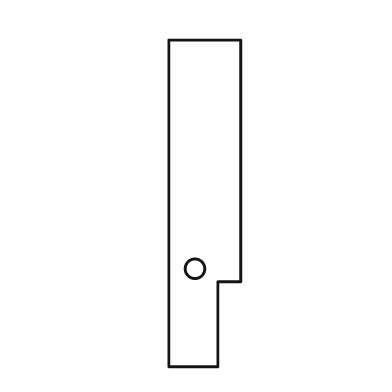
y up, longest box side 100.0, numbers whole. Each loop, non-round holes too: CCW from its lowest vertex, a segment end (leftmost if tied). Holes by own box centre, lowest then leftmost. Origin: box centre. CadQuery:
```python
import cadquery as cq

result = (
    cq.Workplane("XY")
    .moveTo(-11.0, -50.0)
    .lineTo(4.0, -50.0)
    .lineTo(4.0, -24.0)
    .lineTo(11.0, -24.0)
    .lineTo(11.0, 50.0)
    .lineTo(-11.0, 50.0)
    .close()
    .moveTo(-3.0, -20.0)
    .circle(3.0)
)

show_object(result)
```